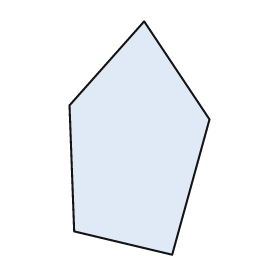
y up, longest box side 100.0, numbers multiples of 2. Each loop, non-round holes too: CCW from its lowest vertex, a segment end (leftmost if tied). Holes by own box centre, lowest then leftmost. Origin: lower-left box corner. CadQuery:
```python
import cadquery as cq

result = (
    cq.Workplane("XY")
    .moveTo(44.0, 0.0)
    .lineTo(60.0, 58.0)
    .lineTo(32.0, 100.0)
    .lineTo(0.0, 64.0)
    .lineTo(2.0, 10.0)
    .close()
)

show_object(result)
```